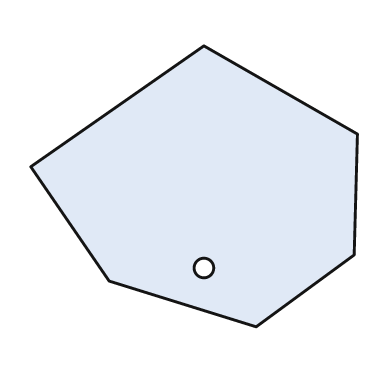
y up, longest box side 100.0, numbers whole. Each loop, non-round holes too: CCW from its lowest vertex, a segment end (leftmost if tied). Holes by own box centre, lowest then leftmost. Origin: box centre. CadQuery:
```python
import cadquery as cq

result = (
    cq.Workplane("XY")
    .moveTo(19.0, -43.0)
    .lineTo(49.0, -21.0)
    .lineTo(50.0, 16.0)
    .lineTo(3.0, 43.0)
    .lineTo(-50.0, 6.0)
    .lineTo(-26.0, -29.0)
    .close()
    .moveTo(3.0, -25.0)
    .circle(3.0)
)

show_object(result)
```